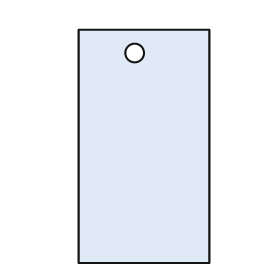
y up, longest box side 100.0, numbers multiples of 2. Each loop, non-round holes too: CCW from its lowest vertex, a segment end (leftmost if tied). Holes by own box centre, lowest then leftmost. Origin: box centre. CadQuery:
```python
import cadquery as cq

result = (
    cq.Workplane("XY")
    .moveTo(-28.0, -50.0)
    .lineTo(28.0, -50.0)
    .lineTo(28.0, 50.0)
    .lineTo(-28.0, 50.0)
    .close()
    .moveTo(-4.0, 40.0)
    .circle(4.0)
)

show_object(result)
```